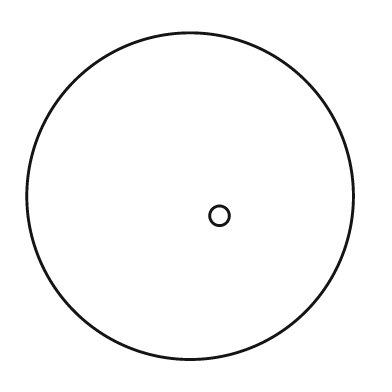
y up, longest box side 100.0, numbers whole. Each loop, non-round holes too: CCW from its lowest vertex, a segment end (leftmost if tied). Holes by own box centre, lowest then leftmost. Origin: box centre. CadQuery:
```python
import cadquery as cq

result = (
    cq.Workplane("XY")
    .moveTo(0.0, 0.0)
    .circle(50.0)
    .moveTo(9.0, -6.0)
    .circle(3.0)
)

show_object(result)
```